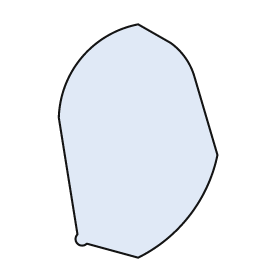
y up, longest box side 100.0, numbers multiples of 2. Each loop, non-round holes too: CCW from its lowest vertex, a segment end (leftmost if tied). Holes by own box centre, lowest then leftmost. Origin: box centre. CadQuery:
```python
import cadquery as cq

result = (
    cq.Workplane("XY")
    .moveTo(0.0, -50.0)
    .threePointArc((22.0, -32.0), (34.0, -6.0))
    .lineTo(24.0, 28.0)
    .threePointArc((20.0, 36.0), (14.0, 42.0))
    .lineTo(0.0, 50.0)
    .threePointArc((-24.0, 36.0), (-34.0, 10.0))
    .lineTo(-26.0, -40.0)
    .threePointArc((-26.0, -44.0), (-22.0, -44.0))
    .close()
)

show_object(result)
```